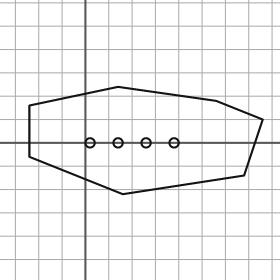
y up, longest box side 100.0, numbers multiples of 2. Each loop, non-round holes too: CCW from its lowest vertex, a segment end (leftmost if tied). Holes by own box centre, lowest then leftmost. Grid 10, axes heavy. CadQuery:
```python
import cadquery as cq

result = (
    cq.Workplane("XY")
    .moveTo(16.0, -22.0)
    .lineTo(68.0, -14.0)
    .lineTo(76.0, 10.0)
    .lineTo(56.0, 18.0)
    .lineTo(14.0, 24.0)
    .lineTo(-24.0, 16.0)
    .lineTo(-24.0, -6.0)
    .close()
    .moveTo(2.0, 0.0)
    .circle(2.0)
    .moveTo(14.0, 0.0)
    .circle(2.0)
    .moveTo(26.0, 0.0)
    .circle(2.0)
    .moveTo(38.0, 0.0)
    .circle(2.0)
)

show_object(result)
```